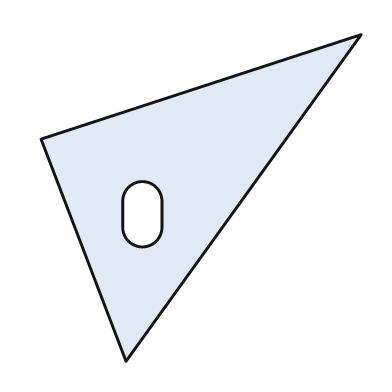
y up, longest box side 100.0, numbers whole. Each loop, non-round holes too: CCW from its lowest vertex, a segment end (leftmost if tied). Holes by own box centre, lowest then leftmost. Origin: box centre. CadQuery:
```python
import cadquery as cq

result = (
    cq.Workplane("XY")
    .moveTo(-23.0, -50.0)
    .lineTo(49.0, 50.0)
    .lineTo(-49.0, 18.0)
    .close()
    .moveTo(-24.0, -9.0)
    .threePointArc((-18.0, -15.0), (-12.0, -9.0))
    .lineTo(-12.0, -1.0)
    .threePointArc((-18.0, 5.0), (-24.0, -1.0))
    .close()
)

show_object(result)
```